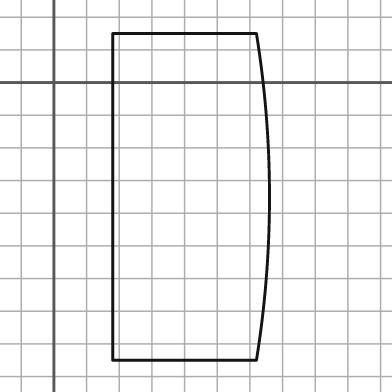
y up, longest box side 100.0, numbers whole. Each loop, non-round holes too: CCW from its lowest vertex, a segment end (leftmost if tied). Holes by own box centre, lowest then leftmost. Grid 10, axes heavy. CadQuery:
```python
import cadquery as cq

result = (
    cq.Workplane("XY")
    .moveTo(18.0, -85.0)
    .lineTo(62.0, -85.0)
    .threePointArc((66.0, -35.0), (62.0, 15.0))
    .lineTo(18.0, 15.0)
    .close()
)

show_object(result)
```